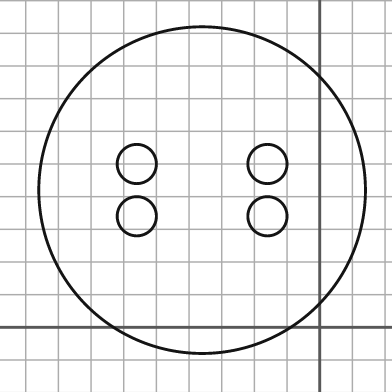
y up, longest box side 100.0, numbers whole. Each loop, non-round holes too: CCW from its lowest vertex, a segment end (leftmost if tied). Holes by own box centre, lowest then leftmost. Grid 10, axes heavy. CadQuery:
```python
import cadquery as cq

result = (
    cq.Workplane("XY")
    .moveTo(-36.0, 42.0)
    .circle(50.0)
    .moveTo(-56.0, 34.0)
    .circle(6.0)
    .moveTo(-16.0, 34.0)
    .circle(6.0)
    .moveTo(-56.0, 50.0)
    .circle(6.0)
    .moveTo(-16.0, 50.0)
    .circle(6.0)
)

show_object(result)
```